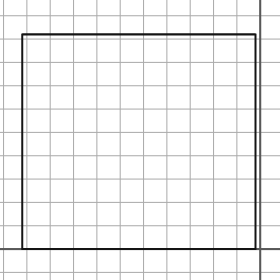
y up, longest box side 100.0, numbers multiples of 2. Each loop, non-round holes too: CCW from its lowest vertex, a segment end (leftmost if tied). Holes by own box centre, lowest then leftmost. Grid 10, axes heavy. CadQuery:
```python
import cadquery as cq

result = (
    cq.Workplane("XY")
    .moveTo(-102.0, 0.0)
    .lineTo(-2.0, 0.0)
    .lineTo(-2.0, 92.0)
    .lineTo(-102.0, 92.0)
    .close()
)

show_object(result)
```